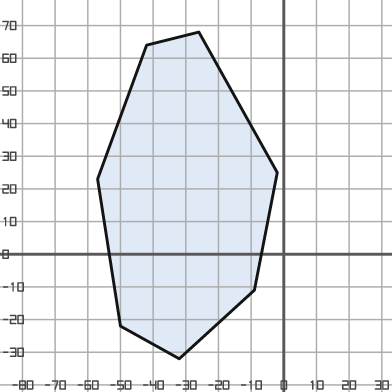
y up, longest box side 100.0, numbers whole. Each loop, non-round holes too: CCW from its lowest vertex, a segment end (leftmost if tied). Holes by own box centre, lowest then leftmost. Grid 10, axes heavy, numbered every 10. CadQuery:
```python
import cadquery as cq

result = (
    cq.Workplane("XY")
    .moveTo(-32.0, -32.0)
    .lineTo(-9.0, -11.0)
    .lineTo(-2.0, 25.0)
    .lineTo(-26.0, 68.0)
    .lineTo(-42.0, 64.0)
    .lineTo(-57.0, 23.0)
    .lineTo(-50.0, -22.0)
    .close()
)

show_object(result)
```